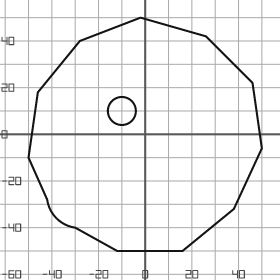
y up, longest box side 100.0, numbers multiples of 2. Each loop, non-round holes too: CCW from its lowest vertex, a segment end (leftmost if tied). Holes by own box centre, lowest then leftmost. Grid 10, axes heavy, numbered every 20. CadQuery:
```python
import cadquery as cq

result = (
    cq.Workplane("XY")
    .moveTo(-12.0, -50.0)
    .lineTo(16.0, -50.0)
    .lineTo(38.0, -32.0)
    .lineTo(50.0, -6.0)
    .lineTo(46.0, 22.0)
    .lineTo(26.0, 42.0)
    .lineTo(-2.0, 50.0)
    .lineTo(-28.0, 40.0)
    .lineTo(-46.0, 18.0)
    .lineTo(-50.0, -10.0)
    .lineTo(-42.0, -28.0)
    .threePointArc((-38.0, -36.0), (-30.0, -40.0))
    .close()
    .moveTo(-10.0, 10.0)
    .circle(6.0)
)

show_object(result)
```